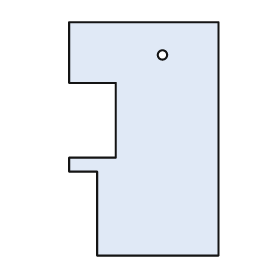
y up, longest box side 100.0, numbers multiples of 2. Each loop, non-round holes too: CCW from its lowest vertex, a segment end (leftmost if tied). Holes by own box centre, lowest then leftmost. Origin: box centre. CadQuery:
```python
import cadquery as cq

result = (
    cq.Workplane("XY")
    .moveTo(-20.0, -50.0)
    .lineTo(32.0, -50.0)
    .lineTo(32.0, 50.0)
    .lineTo(-32.0, 50.0)
    .lineTo(-32.0, 24.0)
    .lineTo(-12.0, 24.0)
    .lineTo(-12.0, -8.0)
    .lineTo(-32.0, -8.0)
    .lineTo(-32.0, -14.0)
    .lineTo(-20.0, -14.0)
    .close()
    .moveTo(8.0, 36.0)
    .circle(2.0)
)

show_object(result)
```